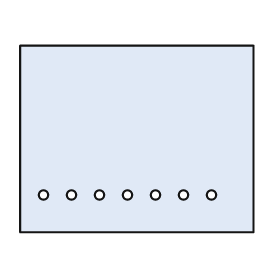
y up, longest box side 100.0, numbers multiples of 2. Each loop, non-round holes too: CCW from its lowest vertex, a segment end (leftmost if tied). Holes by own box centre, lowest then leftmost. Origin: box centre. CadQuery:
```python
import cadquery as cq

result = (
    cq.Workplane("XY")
    .moveTo(-50.0, -40.0)
    .lineTo(50.0, -40.0)
    .lineTo(50.0, 40.0)
    .lineTo(-50.0, 40.0)
    .close()
    .moveTo(-40.0, -24.0)
    .circle(2.0)
    .moveTo(-28.0, -24.0)
    .circle(2.0)
    .moveTo(-16.0, -24.0)
    .circle(2.0)
    .moveTo(-4.0, -24.0)
    .circle(2.0)
    .moveTo(8.0, -24.0)
    .circle(2.0)
    .moveTo(20.0, -24.0)
    .circle(2.0)
    .moveTo(32.0, -24.0)
    .circle(2.0)
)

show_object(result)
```